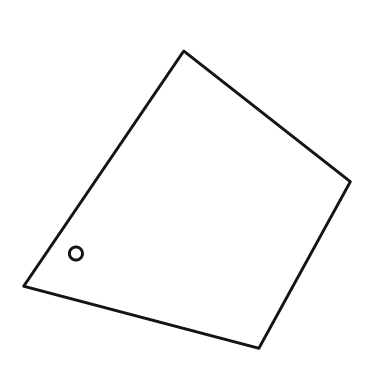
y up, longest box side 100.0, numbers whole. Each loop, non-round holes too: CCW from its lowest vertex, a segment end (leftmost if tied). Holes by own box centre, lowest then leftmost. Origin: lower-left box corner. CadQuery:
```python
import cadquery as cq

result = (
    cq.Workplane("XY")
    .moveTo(72.0, 0.0)
    .lineTo(100.0, 51.0)
    .lineTo(49.0, 91.0)
    .lineTo(0.0, 19.0)
    .close()
    .moveTo(16.0, 29.0)
    .circle(2.0)
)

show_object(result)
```